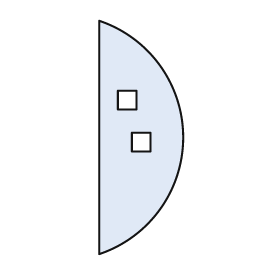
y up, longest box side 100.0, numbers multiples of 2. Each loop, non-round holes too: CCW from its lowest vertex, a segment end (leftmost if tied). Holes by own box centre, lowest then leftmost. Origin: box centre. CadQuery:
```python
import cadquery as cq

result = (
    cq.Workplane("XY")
    .moveTo(-18.0, -50.0)
    .threePointArc((18.0, 0.0), (-18.0, 50.0))
    .close()
    .moveTo(-4.0, -6.0)
    .lineTo(4.0, -6.0)
    .lineTo(4.0, 2.0)
    .lineTo(-4.0, 2.0)
    .close()
    .moveTo(-10.0, 12.0)
    .lineTo(-2.0, 12.0)
    .lineTo(-2.0, 20.0)
    .lineTo(-10.0, 20.0)
    .close()
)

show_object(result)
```